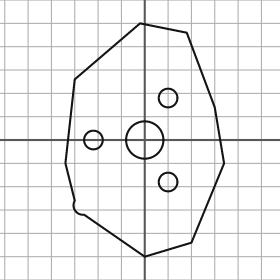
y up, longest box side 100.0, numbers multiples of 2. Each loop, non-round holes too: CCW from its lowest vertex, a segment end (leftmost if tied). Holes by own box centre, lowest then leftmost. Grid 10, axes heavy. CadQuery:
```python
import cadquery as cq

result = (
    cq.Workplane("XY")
    .moveTo(0.0, -50.0)
    .lineTo(20.0, -44.0)
    .lineTo(34.0, -10.0)
    .lineTo(30.0, 14.0)
    .lineTo(18.0, 46.0)
    .lineTo(-2.0, 50.0)
    .lineTo(-30.0, 26.0)
    .lineTo(-34.0, -10.0)
    .lineTo(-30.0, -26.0)
    .threePointArc((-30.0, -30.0), (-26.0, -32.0))
    .close()
    .moveTo(10.0, -18.0)
    .circle(4.0)
    .moveTo(-22.0, 0.0)
    .circle(4.0)
    .moveTo(0.0, 0.0)
    .circle(8.0)
    .moveTo(10.0, 18.0)
    .circle(4.0)
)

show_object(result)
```